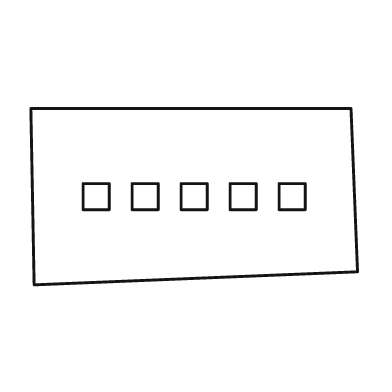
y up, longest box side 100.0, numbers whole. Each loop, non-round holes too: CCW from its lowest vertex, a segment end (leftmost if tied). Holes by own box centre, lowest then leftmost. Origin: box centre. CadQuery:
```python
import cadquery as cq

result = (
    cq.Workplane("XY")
    .moveTo(-49.0, -27.0)
    .lineTo(50.0, -23.0)
    .lineTo(48.0, 27.0)
    .lineTo(-50.0, 27.0)
    .close()
    .moveTo(-34.0, -4.0)
    .lineTo(-26.0, -4.0)
    .lineTo(-26.0, 4.0)
    .lineTo(-34.0, 4.0)
    .close()
    .moveTo(-19.0, -4.0)
    .lineTo(-11.0, -4.0)
    .lineTo(-11.0, 4.0)
    .lineTo(-19.0, 4.0)
    .close()
    .moveTo(-4.0, -4.0)
    .lineTo(4.0, -4.0)
    .lineTo(4.0, 4.0)
    .lineTo(-4.0, 4.0)
    .close()
    .moveTo(11.0, -4.0)
    .lineTo(19.0, -4.0)
    .lineTo(19.0, 4.0)
    .lineTo(11.0, 4.0)
    .close()
    .moveTo(26.0, -4.0)
    .lineTo(34.0, -4.0)
    .lineTo(34.0, 4.0)
    .lineTo(26.0, 4.0)
    .close()
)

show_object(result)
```